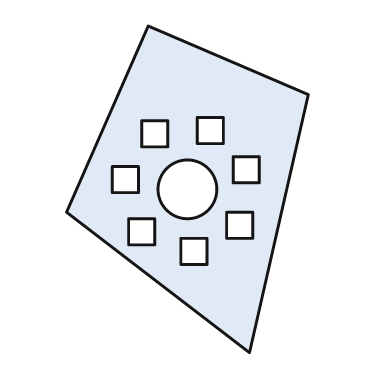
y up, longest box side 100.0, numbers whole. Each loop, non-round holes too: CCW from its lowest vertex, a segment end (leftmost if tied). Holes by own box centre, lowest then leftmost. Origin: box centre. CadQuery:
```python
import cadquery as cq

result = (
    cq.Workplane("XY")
    .moveTo(19.0, -50.0)
    .lineTo(37.0, 29.0)
    .lineTo(-12.0, 50.0)
    .lineTo(-37.0, -7.0)
    .close()
    .moveTo(-2.0, -23.0)
    .lineTo(6.0, -23.0)
    .lineTo(6.0, -15.0)
    .lineTo(-2.0, -15.0)
    .close()
    .moveTo(-18.0, -17.0)
    .lineTo(-10.0, -17.0)
    .lineTo(-10.0, -9.0)
    .lineTo(-18.0, -9.0)
    .close()
    .moveTo(12.0, -15.0)
    .lineTo(20.0, -15.0)
    .lineTo(20.0, -7.0)
    .lineTo(12.0, -7.0)
    .close()
    .moveTo(0.0, 0.0)
    .circle(9.0)
    .moveTo(-23.0, -1.0)
    .lineTo(-15.0, -1.0)
    .lineTo(-15.0, 7.0)
    .lineTo(-23.0, 7.0)
    .close()
    .moveTo(14.0, 2.0)
    .lineTo(22.0, 2.0)
    .lineTo(22.0, 10.0)
    .lineTo(14.0, 10.0)
    .close()
    .moveTo(-14.0, 13.0)
    .lineTo(-6.0, 13.0)
    .lineTo(-6.0, 21.0)
    .lineTo(-14.0, 21.0)
    .close()
    .moveTo(3.0, 14.0)
    .lineTo(11.0, 14.0)
    .lineTo(11.0, 22.0)
    .lineTo(3.0, 22.0)
    .close()
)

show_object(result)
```